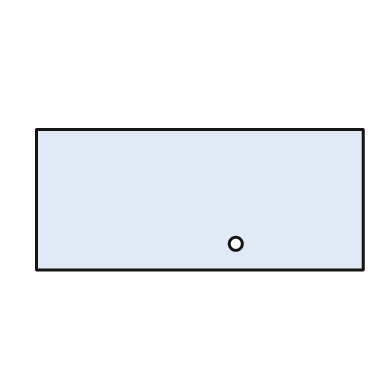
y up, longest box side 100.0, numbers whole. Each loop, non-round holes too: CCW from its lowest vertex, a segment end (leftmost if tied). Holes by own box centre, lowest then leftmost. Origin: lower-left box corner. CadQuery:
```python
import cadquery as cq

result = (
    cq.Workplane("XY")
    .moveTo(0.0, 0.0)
    .lineTo(100.0, 0.0)
    .lineTo(100.0, 43.0)
    .lineTo(0.0, 43.0)
    .close()
    .moveTo(61.0, 8.0)
    .circle(2.0)
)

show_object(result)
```